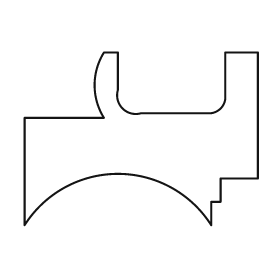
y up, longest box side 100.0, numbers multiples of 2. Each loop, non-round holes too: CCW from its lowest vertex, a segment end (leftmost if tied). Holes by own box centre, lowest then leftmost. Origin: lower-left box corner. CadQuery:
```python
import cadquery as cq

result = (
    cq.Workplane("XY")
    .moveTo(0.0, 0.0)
    .threePointArc((40.0, 22.0), (80.0, 0.0))
    .lineTo(80.0, 10.0)
    .lineTo(84.0, 10.0)
    .lineTo(84.0, 20.0)
    .lineTo(100.0, 20.0)
    .lineTo(100.0, 74.0)
    .lineTo(86.0, 74.0)
    .lineTo(86.0, 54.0)
    .threePointArc((84.0, 50.0), (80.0, 48.0))
    .lineTo(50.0, 48.0)
    .threePointArc((42.0, 50.0), (40.0, 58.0))
    .lineTo(40.0, 74.0)
    .lineTo(34.0, 74.0)
    .threePointArc((30.0, 60.0), (34.0, 46.0))
    .lineTo(0.0, 46.0)
    .close()
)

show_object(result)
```